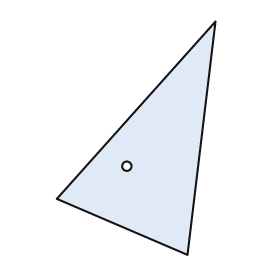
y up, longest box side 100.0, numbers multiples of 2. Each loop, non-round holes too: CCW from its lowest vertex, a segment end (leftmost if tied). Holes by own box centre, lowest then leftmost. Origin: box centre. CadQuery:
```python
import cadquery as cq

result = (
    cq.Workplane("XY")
    .moveTo(22.0, -50.0)
    .lineTo(34.0, 50.0)
    .lineTo(-34.0, -26.0)
    .close()
    .moveTo(-4.0, -12.0)
    .circle(2.0)
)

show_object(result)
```